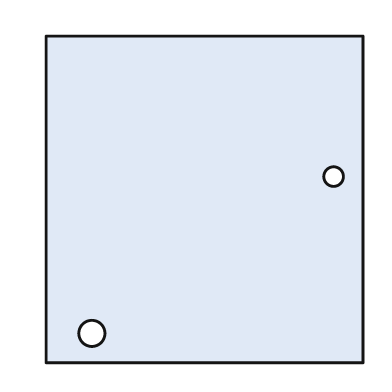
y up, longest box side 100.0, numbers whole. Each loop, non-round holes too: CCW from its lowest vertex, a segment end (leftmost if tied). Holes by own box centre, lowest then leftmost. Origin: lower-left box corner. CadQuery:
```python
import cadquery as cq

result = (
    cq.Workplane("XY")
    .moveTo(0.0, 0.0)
    .lineTo(97.0, 0.0)
    .lineTo(97.0, 100.0)
    .lineTo(0.0, 100.0)
    .close()
    .moveTo(14.0, 9.0)
    .circle(4.0)
    .moveTo(88.0, 57.0)
    .circle(3.0)
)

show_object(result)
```